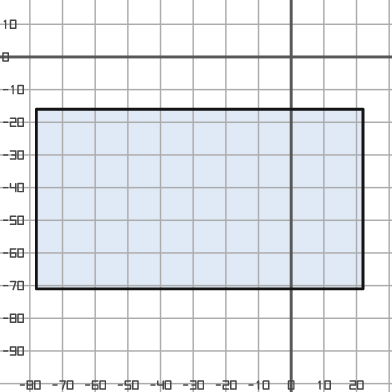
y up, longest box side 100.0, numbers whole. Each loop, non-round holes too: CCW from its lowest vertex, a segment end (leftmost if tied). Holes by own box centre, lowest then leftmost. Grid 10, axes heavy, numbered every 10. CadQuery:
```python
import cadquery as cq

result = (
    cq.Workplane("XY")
    .moveTo(-78.0, -71.0)
    .lineTo(22.0, -71.0)
    .lineTo(22.0, -16.0)
    .lineTo(-78.0, -16.0)
    .close()
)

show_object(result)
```